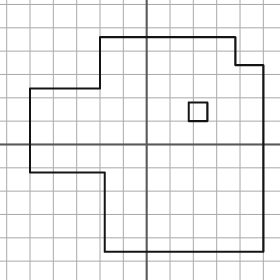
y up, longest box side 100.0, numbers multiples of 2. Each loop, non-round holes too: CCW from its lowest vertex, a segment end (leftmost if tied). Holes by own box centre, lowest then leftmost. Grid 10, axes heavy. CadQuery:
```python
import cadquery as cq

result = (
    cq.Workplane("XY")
    .moveTo(-18.0, -46.0)
    .lineTo(50.0, -46.0)
    .lineTo(50.0, 34.0)
    .lineTo(38.0, 34.0)
    .lineTo(38.0, 46.0)
    .lineTo(-20.0, 46.0)
    .lineTo(-20.0, 24.0)
    .lineTo(-50.0, 24.0)
    .lineTo(-50.0, -12.0)
    .lineTo(-18.0, -12.0)
    .close()
    .moveTo(18.0, 10.0)
    .lineTo(26.0, 10.0)
    .lineTo(26.0, 18.0)
    .lineTo(18.0, 18.0)
    .close()
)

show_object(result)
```